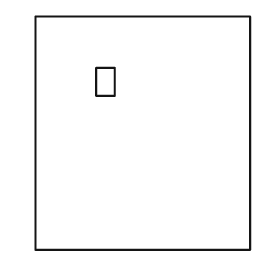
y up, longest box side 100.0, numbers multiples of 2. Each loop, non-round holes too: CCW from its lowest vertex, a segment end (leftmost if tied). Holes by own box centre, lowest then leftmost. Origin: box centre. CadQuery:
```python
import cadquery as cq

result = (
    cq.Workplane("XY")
    .moveTo(-46.0, -50.0)
    .lineTo(46.0, -50.0)
    .lineTo(46.0, 50.0)
    .lineTo(-46.0, 50.0)
    .close()
    .moveTo(-20.0, 16.0)
    .lineTo(-12.0, 16.0)
    .lineTo(-12.0, 28.0)
    .lineTo(-20.0, 28.0)
    .close()
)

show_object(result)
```